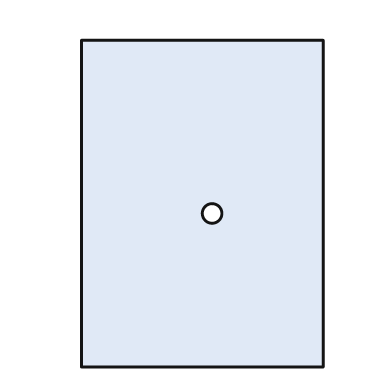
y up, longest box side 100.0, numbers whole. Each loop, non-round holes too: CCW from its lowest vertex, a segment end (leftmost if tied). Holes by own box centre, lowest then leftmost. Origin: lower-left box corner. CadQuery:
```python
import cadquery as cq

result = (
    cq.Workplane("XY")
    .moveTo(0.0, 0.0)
    .lineTo(74.0, 0.0)
    .lineTo(74.0, 100.0)
    .lineTo(0.0, 100.0)
    .close()
    .moveTo(40.0, 47.0)
    .circle(3.0)
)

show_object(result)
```